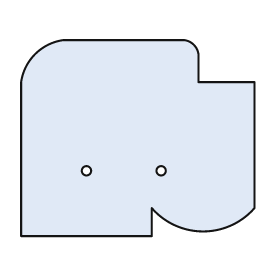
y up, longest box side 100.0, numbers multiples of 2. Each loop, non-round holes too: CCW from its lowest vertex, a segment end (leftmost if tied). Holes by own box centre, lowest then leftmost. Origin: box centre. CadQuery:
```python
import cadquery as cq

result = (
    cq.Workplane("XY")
    .moveTo(-50.0, -42.0)
    .lineTo(6.0, -42.0)
    .lineTo(6.0, -30.0)
    .threePointArc((28.0, -40.0), (50.0, -30.0))
    .lineTo(50.0, 24.0)
    .lineTo(26.0, 24.0)
    .lineTo(26.0, 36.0)
    .threePointArc((24.0, 40.0), (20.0, 42.0))
    .lineTo(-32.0, 42.0)
    .threePointArc((-44.0, 36.0), (-50.0, 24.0))
    .close()
    .moveTo(-22.0, -14.0)
    .circle(2.0)
    .moveTo(10.0, -14.0)
    .circle(2.0)
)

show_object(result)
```